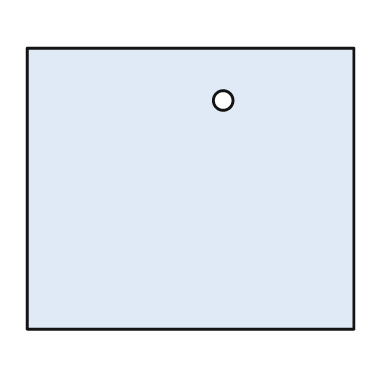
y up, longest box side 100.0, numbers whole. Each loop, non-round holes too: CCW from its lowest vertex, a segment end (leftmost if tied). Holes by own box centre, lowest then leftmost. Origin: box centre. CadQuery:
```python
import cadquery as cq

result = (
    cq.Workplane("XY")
    .moveTo(-50.0, -43.0)
    .lineTo(50.0, -43.0)
    .lineTo(50.0, 43.0)
    .lineTo(-50.0, 43.0)
    .close()
    .moveTo(10.0, 27.0)
    .circle(3.0)
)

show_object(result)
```